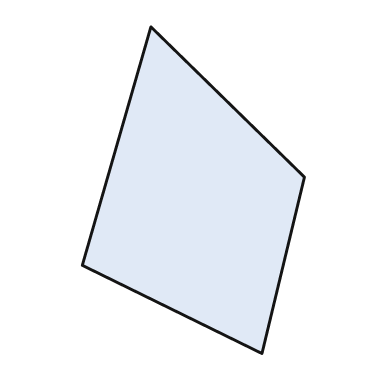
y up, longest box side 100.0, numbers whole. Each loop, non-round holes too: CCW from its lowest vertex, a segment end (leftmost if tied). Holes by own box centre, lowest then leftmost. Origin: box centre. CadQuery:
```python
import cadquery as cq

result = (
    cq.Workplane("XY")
    .moveTo(21.0, -50.0)
    .lineTo(34.0, 4.0)
    .lineTo(-13.0, 50.0)
    .lineTo(-34.0, -23.0)
    .close()
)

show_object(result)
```